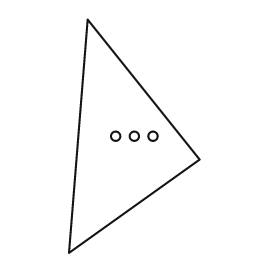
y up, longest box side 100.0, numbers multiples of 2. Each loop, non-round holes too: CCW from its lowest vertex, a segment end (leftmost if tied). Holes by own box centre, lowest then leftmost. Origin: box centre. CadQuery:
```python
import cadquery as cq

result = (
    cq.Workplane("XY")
    .moveTo(-28.0, -50.0)
    .lineTo(28.0, -10.0)
    .lineTo(-20.0, 50.0)
    .close()
    .moveTo(-8.0, 0.0)
    .circle(2.0)
    .moveTo(0.0, 0.0)
    .circle(2.0)
    .moveTo(8.0, 0.0)
    .circle(2.0)
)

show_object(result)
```